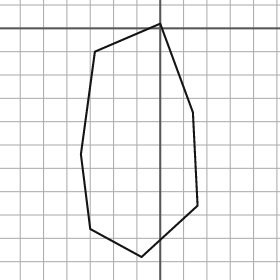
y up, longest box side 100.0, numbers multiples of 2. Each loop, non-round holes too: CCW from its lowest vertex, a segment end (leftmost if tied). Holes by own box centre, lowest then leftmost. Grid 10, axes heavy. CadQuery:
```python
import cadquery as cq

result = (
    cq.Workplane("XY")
    .moveTo(-8.0, -98.0)
    .lineTo(16.0, -76.0)
    .lineTo(14.0, -36.0)
    .lineTo(0.0, 2.0)
    .lineTo(-28.0, -10.0)
    .lineTo(-34.0, -54.0)
    .lineTo(-30.0, -86.0)
    .close()
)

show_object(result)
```